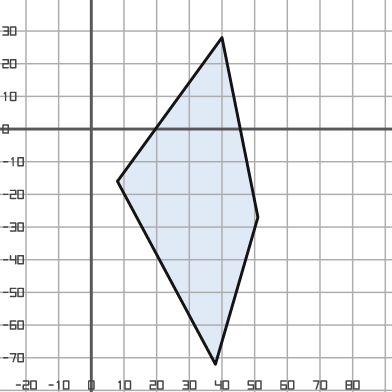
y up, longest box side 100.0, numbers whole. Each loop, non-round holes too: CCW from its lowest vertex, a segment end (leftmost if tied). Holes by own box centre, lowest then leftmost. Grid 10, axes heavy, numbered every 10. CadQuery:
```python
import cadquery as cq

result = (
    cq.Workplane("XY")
    .moveTo(38.0, -72.0)
    .lineTo(51.0, -27.0)
    .lineTo(40.0, 28.0)
    .lineTo(8.0, -16.0)
    .close()
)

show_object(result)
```